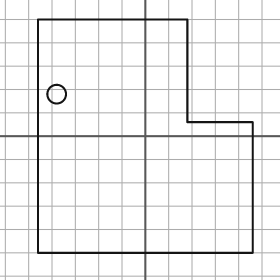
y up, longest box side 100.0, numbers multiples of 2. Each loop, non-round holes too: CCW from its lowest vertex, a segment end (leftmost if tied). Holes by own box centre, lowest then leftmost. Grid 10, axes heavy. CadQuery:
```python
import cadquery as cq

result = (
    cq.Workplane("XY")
    .moveTo(-46.0, -50.0)
    .lineTo(46.0, -50.0)
    .lineTo(46.0, 6.0)
    .lineTo(18.0, 6.0)
    .lineTo(18.0, 50.0)
    .lineTo(-46.0, 50.0)
    .close()
    .moveTo(-38.0, 18.0)
    .circle(4.0)
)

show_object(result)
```